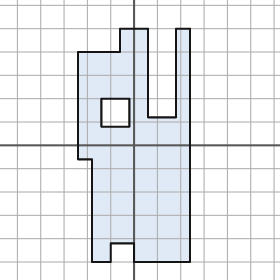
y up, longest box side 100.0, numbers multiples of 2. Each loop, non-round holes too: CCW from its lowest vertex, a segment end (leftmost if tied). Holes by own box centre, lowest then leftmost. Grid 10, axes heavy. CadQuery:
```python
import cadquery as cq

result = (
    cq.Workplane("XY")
    .moveTo(-18.0, -50.0)
    .lineTo(-10.0, -50.0)
    .lineTo(-10.0, -42.0)
    .lineTo(0.0, -42.0)
    .lineTo(0.0, -50.0)
    .lineTo(24.0, -50.0)
    .lineTo(24.0, 50.0)
    .lineTo(18.0, 50.0)
    .lineTo(18.0, 12.0)
    .lineTo(6.0, 12.0)
    .lineTo(6.0, 50.0)
    .lineTo(-6.0, 50.0)
    .lineTo(-6.0, 40.0)
    .lineTo(-24.0, 40.0)
    .lineTo(-24.0, -6.0)
    .lineTo(-18.0, -6.0)
    .close()
    .moveTo(-14.0, 8.0)
    .lineTo(-2.0, 8.0)
    .lineTo(-2.0, 20.0)
    .lineTo(-14.0, 20.0)
    .close()
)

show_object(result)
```